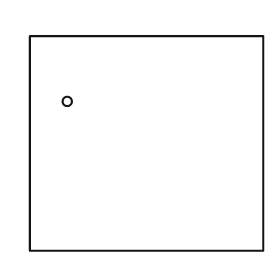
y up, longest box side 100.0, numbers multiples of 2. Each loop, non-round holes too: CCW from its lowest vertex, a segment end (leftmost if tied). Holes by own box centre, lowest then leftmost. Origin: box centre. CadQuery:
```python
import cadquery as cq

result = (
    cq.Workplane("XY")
    .moveTo(-50.0, -46.0)
    .lineTo(50.0, -46.0)
    .lineTo(50.0, 46.0)
    .lineTo(-50.0, 46.0)
    .close()
    .moveTo(-34.0, 18.0)
    .circle(2.0)
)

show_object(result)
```